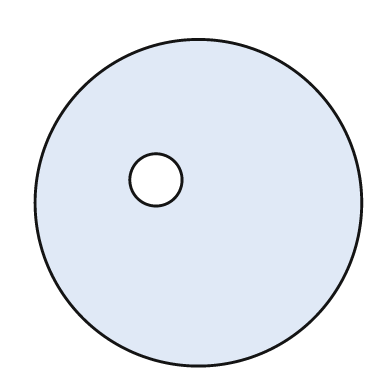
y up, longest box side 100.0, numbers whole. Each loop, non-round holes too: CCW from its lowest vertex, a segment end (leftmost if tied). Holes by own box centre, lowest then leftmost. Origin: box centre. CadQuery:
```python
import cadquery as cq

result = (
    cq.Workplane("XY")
    .moveTo(0.0, 0.0)
    .circle(50.0)
    .moveTo(-13.0, 7.0)
    .circle(8.0)
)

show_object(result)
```